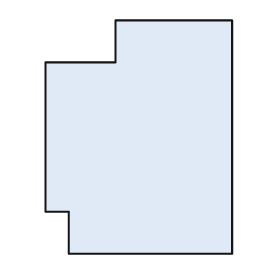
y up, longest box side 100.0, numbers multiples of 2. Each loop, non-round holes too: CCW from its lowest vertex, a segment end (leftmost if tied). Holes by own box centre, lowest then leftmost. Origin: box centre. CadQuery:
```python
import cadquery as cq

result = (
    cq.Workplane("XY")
    .moveTo(-30.0, -50.0)
    .lineTo(40.0, -50.0)
    .lineTo(40.0, 50.0)
    .lineTo(-10.0, 50.0)
    .lineTo(-10.0, 32.0)
    .lineTo(-40.0, 32.0)
    .lineTo(-40.0, -32.0)
    .lineTo(-30.0, -32.0)
    .close()
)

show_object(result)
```